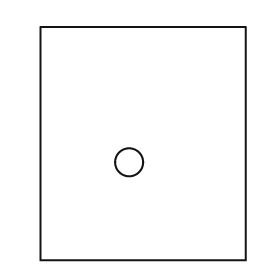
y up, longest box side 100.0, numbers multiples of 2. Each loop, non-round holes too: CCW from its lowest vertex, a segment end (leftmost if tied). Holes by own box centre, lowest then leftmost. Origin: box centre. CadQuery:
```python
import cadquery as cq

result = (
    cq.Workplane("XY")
    .moveTo(-44.0, -50.0)
    .lineTo(44.0, -50.0)
    .lineTo(44.0, 50.0)
    .lineTo(-44.0, 50.0)
    .close()
    .moveTo(-6.0, -8.0)
    .circle(6.0)
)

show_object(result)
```